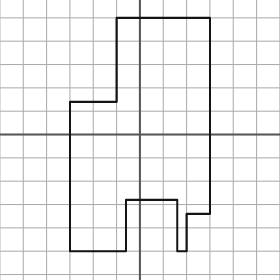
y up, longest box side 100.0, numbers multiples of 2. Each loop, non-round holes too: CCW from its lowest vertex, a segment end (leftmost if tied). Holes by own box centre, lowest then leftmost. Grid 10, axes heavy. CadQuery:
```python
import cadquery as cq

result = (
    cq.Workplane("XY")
    .moveTo(-30.0, -50.0)
    .lineTo(-6.0, -50.0)
    .lineTo(-6.0, -28.0)
    .lineTo(16.0, -28.0)
    .lineTo(16.0, -50.0)
    .lineTo(20.0, -50.0)
    .lineTo(20.0, -34.0)
    .lineTo(30.0, -34.0)
    .lineTo(30.0, 50.0)
    .lineTo(-10.0, 50.0)
    .lineTo(-10.0, 14.0)
    .lineTo(-30.0, 14.0)
    .close()
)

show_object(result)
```